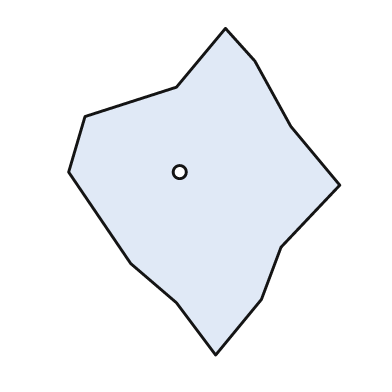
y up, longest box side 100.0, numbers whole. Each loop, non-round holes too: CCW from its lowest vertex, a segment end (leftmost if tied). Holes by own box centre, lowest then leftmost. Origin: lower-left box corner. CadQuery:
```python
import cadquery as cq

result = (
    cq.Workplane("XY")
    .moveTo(45.0, 0.0)
    .lineTo(59.0, 17.0)
    .lineTo(65.0, 33.0)
    .lineTo(83.0, 52.0)
    .lineTo(68.0, 70.0)
    .lineTo(57.0, 90.0)
    .lineTo(48.0, 100.0)
    .lineTo(33.0, 82.0)
    .lineTo(5.0, 73.0)
    .lineTo(0.0, 56.0)
    .lineTo(19.0, 28.0)
    .lineTo(33.0, 16.0)
    .close()
    .moveTo(34.0, 56.0)
    .circle(2.0)
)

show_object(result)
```